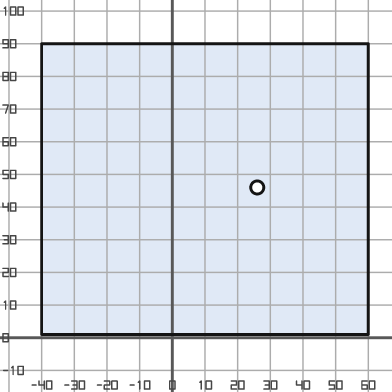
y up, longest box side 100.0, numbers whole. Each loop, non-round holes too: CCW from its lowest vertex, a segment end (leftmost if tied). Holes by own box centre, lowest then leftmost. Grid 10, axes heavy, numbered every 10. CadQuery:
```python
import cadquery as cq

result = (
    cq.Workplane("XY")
    .moveTo(-40.0, 1.0)
    .lineTo(60.0, 1.0)
    .lineTo(60.0, 90.0)
    .lineTo(-40.0, 90.0)
    .close()
    .moveTo(26.0, 46.0)
    .circle(2.0)
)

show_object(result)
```